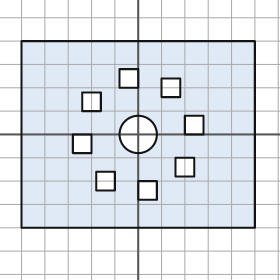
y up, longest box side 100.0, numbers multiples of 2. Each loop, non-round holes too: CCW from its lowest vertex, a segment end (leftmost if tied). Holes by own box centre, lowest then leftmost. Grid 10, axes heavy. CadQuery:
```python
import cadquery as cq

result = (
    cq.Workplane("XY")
    .moveTo(-50.0, -40.0)
    .lineTo(50.0, -40.0)
    .lineTo(50.0, 40.0)
    .lineTo(-50.0, 40.0)
    .close()
    .moveTo(0.0, -28.0)
    .lineTo(8.0, -28.0)
    .lineTo(8.0, -20.0)
    .lineTo(0.0, -20.0)
    .close()
    .moveTo(-18.0, -24.0)
    .lineTo(-10.0, -24.0)
    .lineTo(-10.0, -16.0)
    .lineTo(-18.0, -16.0)
    .close()
    .moveTo(16.0, -18.0)
    .lineTo(24.0, -18.0)
    .lineTo(24.0, -10.0)
    .lineTo(16.0, -10.0)
    .close()
    .moveTo(-28.0, -8.0)
    .lineTo(-20.0, -8.0)
    .lineTo(-20.0, 0.0)
    .lineTo(-28.0, 0.0)
    .close()
    .moveTo(0.0, 0.0)
    .circle(8.0)
    .moveTo(20.0, 0.0)
    .lineTo(28.0, 0.0)
    .lineTo(28.0, 8.0)
    .lineTo(20.0, 8.0)
    .close()
    .moveTo(-24.0, 10.0)
    .lineTo(-16.0, 10.0)
    .lineTo(-16.0, 18.0)
    .lineTo(-24.0, 18.0)
    .close()
    .moveTo(10.0, 16.0)
    .lineTo(18.0, 16.0)
    .lineTo(18.0, 24.0)
    .lineTo(10.0, 24.0)
    .close()
    .moveTo(-8.0, 20.0)
    .lineTo(0.0, 20.0)
    .lineTo(0.0, 28.0)
    .lineTo(-8.0, 28.0)
    .close()
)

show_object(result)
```